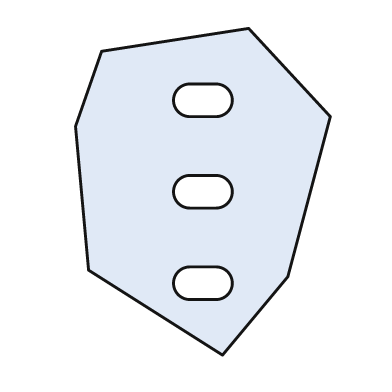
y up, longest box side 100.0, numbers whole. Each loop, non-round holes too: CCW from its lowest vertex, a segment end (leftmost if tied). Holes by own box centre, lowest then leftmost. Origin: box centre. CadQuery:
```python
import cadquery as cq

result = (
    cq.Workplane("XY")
    .moveTo(6.0, -50.0)
    .lineTo(26.0, -26.0)
    .lineTo(39.0, 23.0)
    .lineTo(14.0, 50.0)
    .lineTo(-31.0, 43.0)
    .lineTo(-39.0, 20.0)
    .lineTo(-35.0, -24.0)
    .close()
    .moveTo(-4.0, -33.0)
    .lineTo(4.0, -33.0)
    .threePointArc((9.0, -28.0), (4.0, -23.0))
    .lineTo(-4.0, -23.0)
    .threePointArc((-9.0, -28.0), (-4.0, -33.0))
    .close()
    .moveTo(-4.0, -5.0)
    .lineTo(4.0, -5.0)
    .threePointArc((9.0, 0.0), (4.0, 5.0))
    .lineTo(-4.0, 5.0)
    .threePointArc((-9.0, 0.0), (-4.0, -5.0))
    .close()
    .moveTo(-4.0, 23.0)
    .lineTo(4.0, 23.0)
    .threePointArc((9.0, 28.0), (4.0, 33.0))
    .lineTo(-4.0, 33.0)
    .threePointArc((-9.0, 28.0), (-4.0, 23.0))
    .close()
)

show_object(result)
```